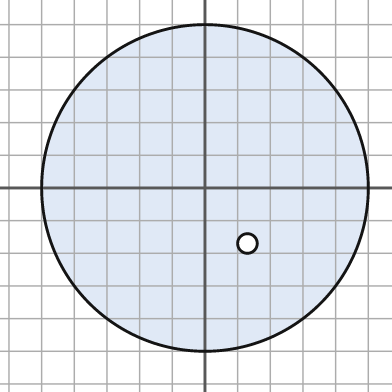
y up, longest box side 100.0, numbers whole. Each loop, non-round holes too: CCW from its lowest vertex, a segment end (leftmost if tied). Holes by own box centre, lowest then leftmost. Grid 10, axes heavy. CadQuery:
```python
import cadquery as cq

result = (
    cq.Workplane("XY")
    .moveTo(0.0, 0.0)
    .circle(50.0)
    .moveTo(13.0, -17.0)
    .circle(3.0)
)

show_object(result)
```